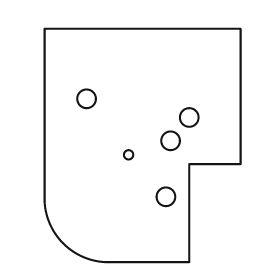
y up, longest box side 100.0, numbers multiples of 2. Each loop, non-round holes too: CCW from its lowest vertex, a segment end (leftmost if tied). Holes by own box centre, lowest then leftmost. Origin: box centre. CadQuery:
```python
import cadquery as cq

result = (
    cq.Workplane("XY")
    .moveTo(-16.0, -50.0)
    .lineTo(20.0, -50.0)
    .lineTo(20.0, -8.0)
    .lineTo(42.0, -8.0)
    .lineTo(42.0, 50.0)
    .lineTo(-42.0, 50.0)
    .lineTo(-42.0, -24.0)
    .threePointArc((-34.0, -42.0), (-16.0, -50.0))
    .close()
    .moveTo(10.0, -22.0)
    .circle(4.0)
    .moveTo(-6.0, -4.0)
    .circle(2.0)
    .moveTo(12.0, 2.0)
    .circle(4.0)
    .moveTo(20.0, 12.0)
    .circle(4.0)
    .moveTo(-24.0, 20.0)
    .circle(4.0)
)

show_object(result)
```